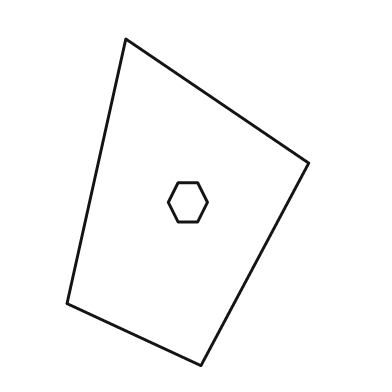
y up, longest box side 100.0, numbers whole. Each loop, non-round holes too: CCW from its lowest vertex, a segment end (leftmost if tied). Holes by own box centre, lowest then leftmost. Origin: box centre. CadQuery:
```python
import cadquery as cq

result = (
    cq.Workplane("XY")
    .moveTo(4.0, -50.0)
    .lineTo(37.0, 12.0)
    .lineTo(-19.0, 50.0)
    .lineTo(-37.0, -31.0)
    .close()
    .moveTo(-3.0, -6.0)
    .lineTo(3.0, -6.0)
    .lineTo(6.0, 0.0)
    .lineTo(3.0, 6.0)
    .lineTo(-3.0, 6.0)
    .lineTo(-6.0, 0.0)
    .close()
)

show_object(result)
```